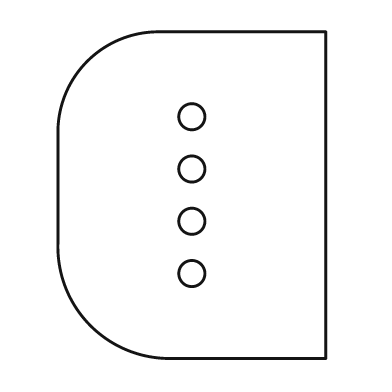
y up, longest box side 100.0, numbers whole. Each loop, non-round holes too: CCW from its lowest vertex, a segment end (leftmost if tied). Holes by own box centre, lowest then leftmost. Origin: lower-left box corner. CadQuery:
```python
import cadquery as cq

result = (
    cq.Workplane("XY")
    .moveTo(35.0, 0.0)
    .lineTo(82.0, 0.0)
    .lineTo(82.0, 100.0)
    .lineTo(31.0, 100.0)
    .threePointArc((9.0, 91.0), (0.0, 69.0))
    .lineTo(0.0, 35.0)
    .threePointArc((10.0, 10.0), (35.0, 0.0))
    .close()
    .moveTo(41.0, 26.0)
    .circle(4.0)
    .moveTo(41.0, 42.0)
    .circle(4.0)
    .moveTo(41.0, 58.0)
    .circle(4.0)
    .moveTo(41.0, 74.0)
    .circle(4.0)
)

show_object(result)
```